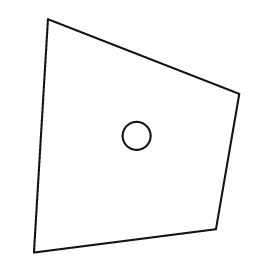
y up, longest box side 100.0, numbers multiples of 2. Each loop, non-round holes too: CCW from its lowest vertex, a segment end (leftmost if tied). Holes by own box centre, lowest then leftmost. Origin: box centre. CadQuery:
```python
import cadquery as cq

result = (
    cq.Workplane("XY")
    .moveTo(-44.0, -50.0)
    .lineTo(34.0, -40.0)
    .lineTo(44.0, 18.0)
    .lineTo(-38.0, 50.0)
    .close()
    .moveTo(0.0, 0.0)
    .circle(6.0)
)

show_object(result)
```